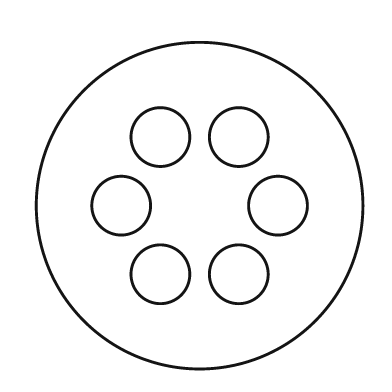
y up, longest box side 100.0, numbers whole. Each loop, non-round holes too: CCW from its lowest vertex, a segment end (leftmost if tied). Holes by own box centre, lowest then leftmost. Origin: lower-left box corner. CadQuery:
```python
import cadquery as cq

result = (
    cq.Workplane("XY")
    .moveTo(50.0, 50.0)
    .circle(50.0)
    .moveTo(38.0, 29.0)
    .circle(9.0)
    .moveTo(62.0, 29.0)
    .circle(9.0)
    .moveTo(26.0, 50.0)
    .circle(9.0)
    .moveTo(74.0, 50.0)
    .circle(9.0)
    .moveTo(38.0, 71.0)
    .circle(9.0)
    .moveTo(62.0, 71.0)
    .circle(9.0)
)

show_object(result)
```